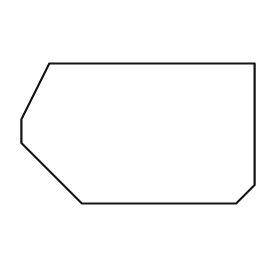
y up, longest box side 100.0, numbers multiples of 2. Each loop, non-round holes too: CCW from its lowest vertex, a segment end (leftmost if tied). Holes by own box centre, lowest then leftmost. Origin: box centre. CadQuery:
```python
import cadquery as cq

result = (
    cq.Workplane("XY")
    .moveTo(-24.0, -30.0)
    .lineTo(42.0, -30.0)
    .lineTo(50.0, -22.0)
    .lineTo(50.0, 30.0)
    .lineTo(-38.0, 30.0)
    .lineTo(-50.0, 6.0)
    .lineTo(-50.0, -4.0)
    .close()
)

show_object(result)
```